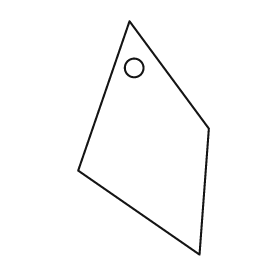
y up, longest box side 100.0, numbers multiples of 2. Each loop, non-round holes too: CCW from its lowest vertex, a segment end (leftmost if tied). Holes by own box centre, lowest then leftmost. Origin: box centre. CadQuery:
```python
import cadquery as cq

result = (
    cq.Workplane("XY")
    .moveTo(24.0, -50.0)
    .lineTo(28.0, 4.0)
    .lineTo(-6.0, 50.0)
    .lineTo(-28.0, -14.0)
    .close()
    .moveTo(-4.0, 30.0)
    .circle(4.0)
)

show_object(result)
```